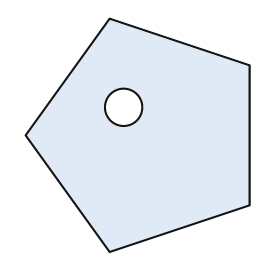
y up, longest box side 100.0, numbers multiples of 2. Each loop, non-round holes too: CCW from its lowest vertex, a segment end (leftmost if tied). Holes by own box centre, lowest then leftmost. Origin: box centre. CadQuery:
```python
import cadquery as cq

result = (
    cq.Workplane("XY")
    .moveTo(-12.0, -50.0)
    .lineTo(48.0, -30.0)
    .lineTo(48.0, 30.0)
    .lineTo(-12.0, 50.0)
    .lineTo(-48.0, 0.0)
    .close()
    .moveTo(-6.0, 12.0)
    .circle(8.0)
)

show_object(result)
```